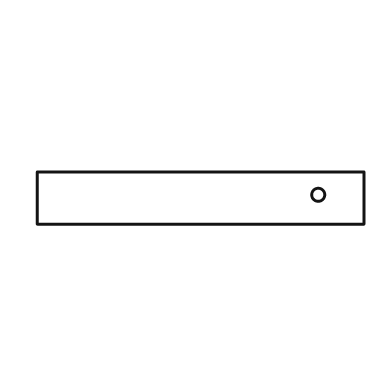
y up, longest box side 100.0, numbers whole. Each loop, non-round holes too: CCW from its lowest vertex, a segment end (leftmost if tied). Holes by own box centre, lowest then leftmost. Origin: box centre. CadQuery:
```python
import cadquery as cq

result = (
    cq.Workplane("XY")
    .moveTo(-50.0, -8.0)
    .lineTo(50.0, -8.0)
    .lineTo(50.0, 8.0)
    .lineTo(-50.0, 8.0)
    .close()
    .moveTo(36.0, 1.0)
    .circle(2.0)
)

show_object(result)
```